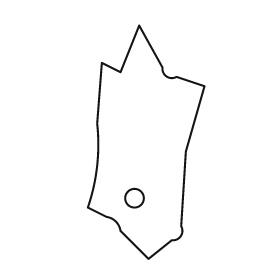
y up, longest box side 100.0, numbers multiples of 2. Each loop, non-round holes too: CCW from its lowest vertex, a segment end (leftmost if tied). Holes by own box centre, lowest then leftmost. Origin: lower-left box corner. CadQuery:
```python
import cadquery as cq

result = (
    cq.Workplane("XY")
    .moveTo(26.0, 0.0)
    .lineTo(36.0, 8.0)
    .threePointArc((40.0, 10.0), (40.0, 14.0))
    .lineTo(42.0, 46.0)
    .lineTo(50.0, 74.0)
    .lineTo(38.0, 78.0)
    .threePointArc((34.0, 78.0), (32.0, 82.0))
    .lineTo(22.0, 100.0)
    .lineTo(14.0, 80.0)
    .lineTo(6.0, 84.0)
    .lineTo(4.0, 58.0)
    .threePointArc((4.0, 40.0), (0.0, 22.0))
    .lineTo(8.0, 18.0)
    .threePointArc((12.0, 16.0), (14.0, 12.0))
    .close()
    .moveTo(20.0, 26.0)
    .circle(4.0)
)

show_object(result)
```